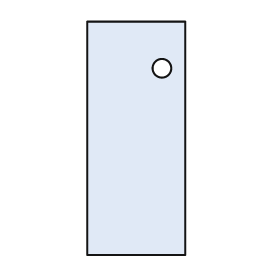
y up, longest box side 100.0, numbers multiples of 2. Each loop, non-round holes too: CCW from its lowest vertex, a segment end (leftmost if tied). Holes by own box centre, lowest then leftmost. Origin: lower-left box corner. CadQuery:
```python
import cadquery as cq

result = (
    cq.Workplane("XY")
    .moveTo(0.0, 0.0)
    .lineTo(42.0, 0.0)
    .lineTo(42.0, 100.0)
    .lineTo(0.0, 100.0)
    .close()
    .moveTo(32.0, 80.0)
    .circle(4.0)
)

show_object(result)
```